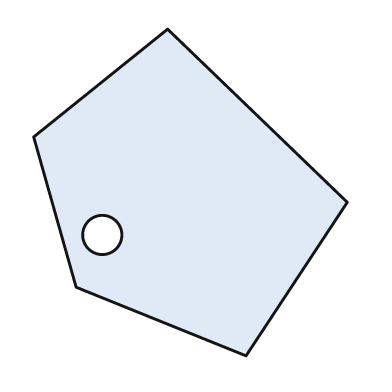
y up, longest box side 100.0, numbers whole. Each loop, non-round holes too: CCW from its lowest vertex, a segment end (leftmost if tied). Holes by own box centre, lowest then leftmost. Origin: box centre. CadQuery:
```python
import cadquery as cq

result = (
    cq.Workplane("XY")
    .moveTo(17.0, -50.0)
    .lineTo(48.0, -3.0)
    .lineTo(-7.0, 50.0)
    .lineTo(-48.0, 17.0)
    .lineTo(-35.0, -29.0)
    .close()
    .moveTo(-27.0, -13.0)
    .circle(6.0)
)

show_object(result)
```